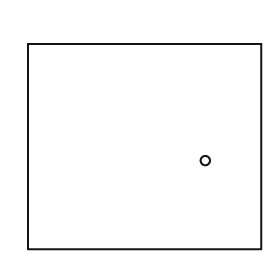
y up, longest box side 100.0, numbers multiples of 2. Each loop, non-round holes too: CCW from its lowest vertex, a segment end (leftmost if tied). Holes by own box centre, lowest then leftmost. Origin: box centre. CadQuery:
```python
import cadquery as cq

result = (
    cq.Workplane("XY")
    .moveTo(-50.0, -44.0)
    .lineTo(50.0, -44.0)
    .lineTo(50.0, 44.0)
    .lineTo(-50.0, 44.0)
    .close()
    .moveTo(26.0, -6.0)
    .circle(2.0)
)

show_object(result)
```